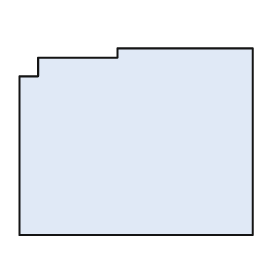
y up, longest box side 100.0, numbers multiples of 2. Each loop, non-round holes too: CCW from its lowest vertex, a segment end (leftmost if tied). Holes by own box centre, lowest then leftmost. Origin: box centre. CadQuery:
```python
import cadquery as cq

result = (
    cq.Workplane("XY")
    .moveTo(-50.0, -40.0)
    .lineTo(50.0, -40.0)
    .lineTo(50.0, 40.0)
    .lineTo(-8.0, 40.0)
    .lineTo(-8.0, 36.0)
    .lineTo(-42.0, 36.0)
    .lineTo(-42.0, 28.0)
    .lineTo(-50.0, 28.0)
    .close()
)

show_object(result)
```